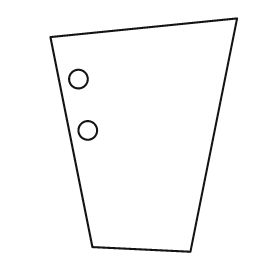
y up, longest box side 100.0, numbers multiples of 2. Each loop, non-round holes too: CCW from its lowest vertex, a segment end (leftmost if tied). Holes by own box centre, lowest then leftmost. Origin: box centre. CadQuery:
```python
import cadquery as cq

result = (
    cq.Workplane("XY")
    .moveTo(20.0, -50.0)
    .lineTo(40.0, 50.0)
    .lineTo(-40.0, 42.0)
    .lineTo(-22.0, -48.0)
    .close()
    .moveTo(-24.0, 2.0)
    .circle(4.0)
    .moveTo(-28.0, 24.0)
    .circle(4.0)
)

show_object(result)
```